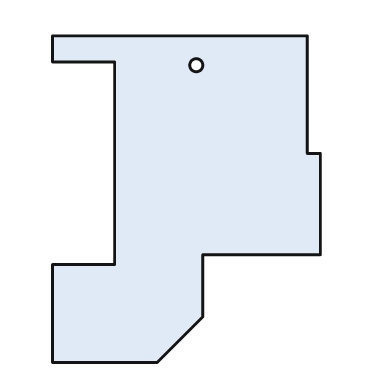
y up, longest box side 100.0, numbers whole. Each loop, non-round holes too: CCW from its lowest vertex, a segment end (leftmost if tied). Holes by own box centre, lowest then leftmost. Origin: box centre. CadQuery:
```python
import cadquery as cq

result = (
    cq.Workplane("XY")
    .moveTo(-41.0, -50.0)
    .lineTo(-9.0, -50.0)
    .lineTo(5.0, -36.0)
    .lineTo(5.0, -17.0)
    .lineTo(41.0, -17.0)
    .lineTo(41.0, 14.0)
    .lineTo(37.0, 14.0)
    .lineTo(37.0, 50.0)
    .lineTo(-41.0, 50.0)
    .lineTo(-41.0, 42.0)
    .lineTo(-22.0, 42.0)
    .lineTo(-22.0, -20.0)
    .lineTo(-41.0, -20.0)
    .close()
    .moveTo(3.0, 41.0)
    .circle(2.0)
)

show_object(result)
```